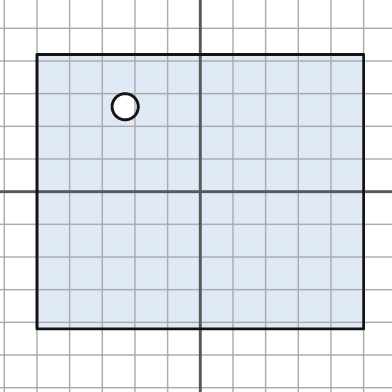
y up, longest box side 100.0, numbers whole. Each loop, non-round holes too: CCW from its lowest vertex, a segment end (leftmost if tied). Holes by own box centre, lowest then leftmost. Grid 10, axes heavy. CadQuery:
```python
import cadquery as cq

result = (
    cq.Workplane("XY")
    .moveTo(-50.0, -42.0)
    .lineTo(50.0, -42.0)
    .lineTo(50.0, 42.0)
    .lineTo(-50.0, 42.0)
    .close()
    .moveTo(-23.0, 26.0)
    .circle(4.0)
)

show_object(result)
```